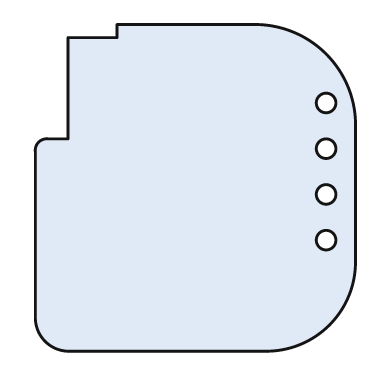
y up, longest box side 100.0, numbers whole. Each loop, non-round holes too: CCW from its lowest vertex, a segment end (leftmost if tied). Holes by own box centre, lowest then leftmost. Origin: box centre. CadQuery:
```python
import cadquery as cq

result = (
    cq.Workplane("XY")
    .moveTo(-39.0, -50.0)
    .lineTo(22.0, -50.0)
    .threePointArc((41.0, -42.0), (49.0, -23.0))
    .lineTo(49.0, 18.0)
    .threePointArc((40.0, 41.0), (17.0, 50.0))
    .lineTo(-24.0, 50.0)
    .lineTo(-24.0, 46.0)
    .lineTo(-39.0, 46.0)
    .lineTo(-39.0, 15.0)
    .lineTo(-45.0, 15.0)
    .threePointArc((-48.0, 14.0), (-49.0, 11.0))
    .lineTo(-49.0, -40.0)
    .threePointArc((-46.0, -47.0), (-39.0, -50.0))
    .close()
    .moveTo(40.0, -16.0)
    .circle(3.0)
    .moveTo(40.0, -2.0)
    .circle(3.0)
    .moveTo(40.0, 12.0)
    .circle(3.0)
    .moveTo(40.0, 26.0)
    .circle(3.0)
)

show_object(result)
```